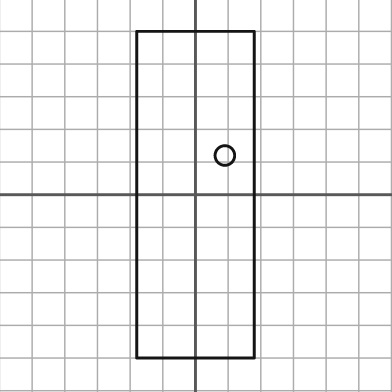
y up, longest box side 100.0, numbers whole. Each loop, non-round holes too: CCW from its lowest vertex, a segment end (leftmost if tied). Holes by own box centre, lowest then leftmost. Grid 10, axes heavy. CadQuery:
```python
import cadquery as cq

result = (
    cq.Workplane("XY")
    .moveTo(-18.0, -50.0)
    .lineTo(18.0, -50.0)
    .lineTo(18.0, 50.0)
    .lineTo(-18.0, 50.0)
    .close()
    .moveTo(9.0, 12.0)
    .circle(3.0)
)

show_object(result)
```